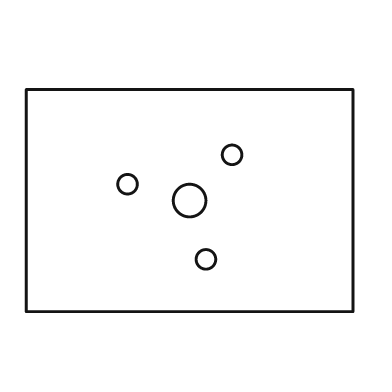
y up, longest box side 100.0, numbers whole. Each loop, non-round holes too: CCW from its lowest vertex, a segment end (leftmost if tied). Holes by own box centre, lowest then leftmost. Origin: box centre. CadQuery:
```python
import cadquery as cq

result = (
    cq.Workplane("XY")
    .moveTo(-50.0, -34.0)
    .lineTo(50.0, -34.0)
    .lineTo(50.0, 34.0)
    .lineTo(-50.0, 34.0)
    .close()
    .moveTo(5.0, -18.0)
    .circle(3.0)
    .moveTo(0.0, 0.0)
    .circle(5.0)
    .moveTo(-19.0, 5.0)
    .circle(3.0)
    .moveTo(13.0, 14.0)
    .circle(3.0)
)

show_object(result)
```